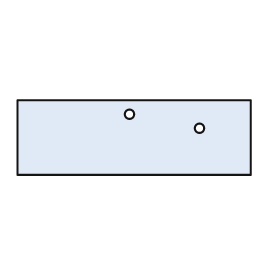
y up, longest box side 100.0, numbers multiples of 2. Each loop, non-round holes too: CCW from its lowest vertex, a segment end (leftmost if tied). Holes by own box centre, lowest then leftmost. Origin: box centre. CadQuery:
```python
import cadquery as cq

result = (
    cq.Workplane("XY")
    .moveTo(-50.0, -16.0)
    .lineTo(50.0, -16.0)
    .lineTo(50.0, 16.0)
    .lineTo(-50.0, 16.0)
    .close()
    .moveTo(28.0, 4.0)
    .circle(2.0)
    .moveTo(-2.0, 10.0)
    .circle(2.0)
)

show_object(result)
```